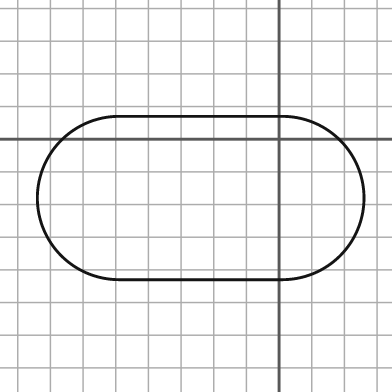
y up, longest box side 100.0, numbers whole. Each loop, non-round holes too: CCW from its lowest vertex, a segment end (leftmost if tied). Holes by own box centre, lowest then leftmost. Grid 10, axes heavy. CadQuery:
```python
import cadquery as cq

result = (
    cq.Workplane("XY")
    .moveTo(-49.0, -43.0)
    .lineTo(1.0, -43.0)
    .threePointArc((26.0, -18.0), (1.0, 7.0))
    .lineTo(-49.0, 7.0)
    .threePointArc((-74.0, -18.0), (-49.0, -43.0))
    .close()
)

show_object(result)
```